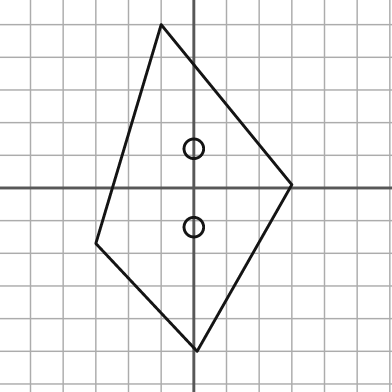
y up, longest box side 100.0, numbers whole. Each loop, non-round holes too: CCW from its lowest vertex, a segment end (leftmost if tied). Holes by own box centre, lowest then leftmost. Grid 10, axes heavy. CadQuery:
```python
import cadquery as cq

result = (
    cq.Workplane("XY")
    .moveTo(1.0, -50.0)
    .lineTo(30.0, 1.0)
    .lineTo(-10.0, 50.0)
    .lineTo(-30.0, -17.0)
    .close()
    .moveTo(0.0, -12.0)
    .circle(3.0)
    .moveTo(0.0, 12.0)
    .circle(3.0)
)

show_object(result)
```